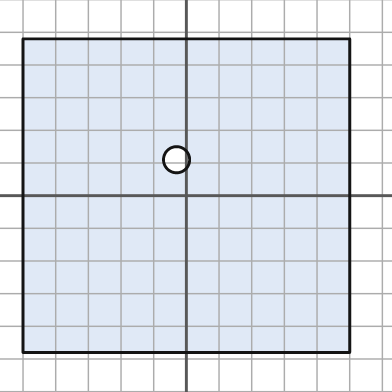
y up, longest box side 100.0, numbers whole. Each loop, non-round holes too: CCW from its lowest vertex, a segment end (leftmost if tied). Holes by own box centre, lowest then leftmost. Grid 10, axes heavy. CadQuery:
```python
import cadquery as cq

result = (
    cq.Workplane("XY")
    .moveTo(-50.0, -48.0)
    .lineTo(50.0, -48.0)
    .lineTo(50.0, 48.0)
    .lineTo(-50.0, 48.0)
    .close()
    .moveTo(-3.0, 11.0)
    .circle(4.0)
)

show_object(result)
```